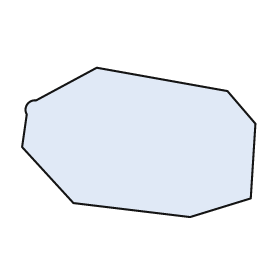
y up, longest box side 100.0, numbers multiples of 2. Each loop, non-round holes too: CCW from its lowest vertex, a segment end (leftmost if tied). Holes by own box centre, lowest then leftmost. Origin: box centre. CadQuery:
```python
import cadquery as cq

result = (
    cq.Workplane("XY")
    .moveTo(22.0, -32.0)
    .lineTo(48.0, -24.0)
    .lineTo(50.0, 8.0)
    .lineTo(38.0, 22.0)
    .lineTo(-18.0, 32.0)
    .lineTo(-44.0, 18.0)
    .threePointArc((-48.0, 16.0), (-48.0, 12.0))
    .lineTo(-50.0, -2.0)
    .lineTo(-28.0, -26.0)
    .close()
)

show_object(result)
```